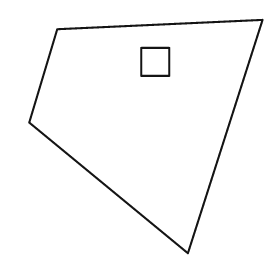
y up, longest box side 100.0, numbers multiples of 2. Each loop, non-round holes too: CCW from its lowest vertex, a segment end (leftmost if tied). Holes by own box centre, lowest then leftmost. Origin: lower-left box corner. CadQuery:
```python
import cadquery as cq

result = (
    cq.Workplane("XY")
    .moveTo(68.0, 0.0)
    .lineTo(100.0, 100.0)
    .lineTo(12.0, 96.0)
    .lineTo(0.0, 56.0)
    .close()
    .moveTo(48.0, 76.0)
    .lineTo(60.0, 76.0)
    .lineTo(60.0, 88.0)
    .lineTo(48.0, 88.0)
    .close()
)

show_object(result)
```